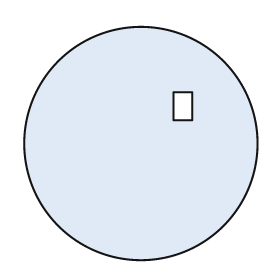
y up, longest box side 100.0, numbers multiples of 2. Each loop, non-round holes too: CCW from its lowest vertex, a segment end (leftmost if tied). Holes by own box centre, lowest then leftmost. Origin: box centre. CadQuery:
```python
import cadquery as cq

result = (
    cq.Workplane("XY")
    .moveTo(0.0, 0.0)
    .circle(50.0)
    .moveTo(14.0, 10.0)
    .lineTo(22.0, 10.0)
    .lineTo(22.0, 22.0)
    .lineTo(14.0, 22.0)
    .close()
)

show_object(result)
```